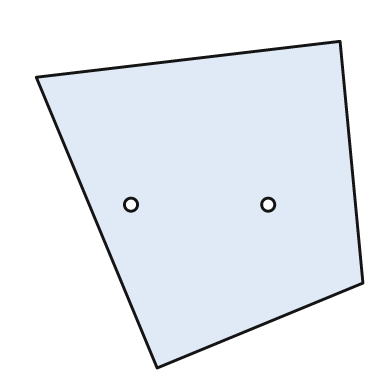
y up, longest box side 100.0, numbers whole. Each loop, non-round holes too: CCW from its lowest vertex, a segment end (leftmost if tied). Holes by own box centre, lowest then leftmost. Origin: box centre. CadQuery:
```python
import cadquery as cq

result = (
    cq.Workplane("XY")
    .moveTo(-13.0, -50.0)
    .lineTo(50.0, -24.0)
    .lineTo(43.0, 50.0)
    .lineTo(-50.0, 39.0)
    .close()
    .moveTo(-21.0, 0.0)
    .circle(2.0)
    .moveTo(21.0, 0.0)
    .circle(2.0)
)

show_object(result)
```